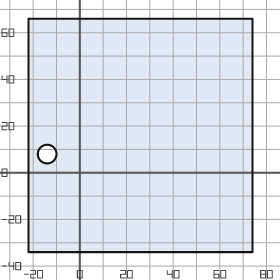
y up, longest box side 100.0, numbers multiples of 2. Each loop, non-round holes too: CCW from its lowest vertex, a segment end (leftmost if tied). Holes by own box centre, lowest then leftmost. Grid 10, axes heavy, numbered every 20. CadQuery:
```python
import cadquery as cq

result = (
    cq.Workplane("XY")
    .moveTo(-22.0, -34.0)
    .lineTo(74.0, -34.0)
    .lineTo(74.0, 66.0)
    .lineTo(-22.0, 66.0)
    .close()
    .moveTo(-14.0, 8.0)
    .circle(4.0)
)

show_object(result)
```